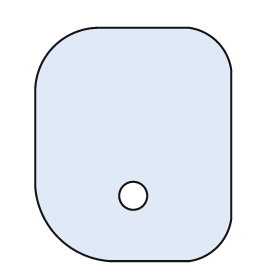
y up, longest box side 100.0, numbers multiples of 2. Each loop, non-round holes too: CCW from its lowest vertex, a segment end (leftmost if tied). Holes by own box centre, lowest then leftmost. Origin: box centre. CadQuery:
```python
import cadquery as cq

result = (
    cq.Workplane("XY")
    .moveTo(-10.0, -50.0)
    .lineTo(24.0, -50.0)
    .threePointArc((36.0, -44.0), (42.0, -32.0))
    .lineTo(42.0, 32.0)
    .threePointArc((36.0, 44.0), (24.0, 50.0))
    .lineTo(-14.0, 50.0)
    .threePointArc((-34.0, 42.0), (-42.0, 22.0))
    .lineTo(-42.0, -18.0)
    .threePointArc((-32.0, -40.0), (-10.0, -50.0))
    .close()
    .moveTo(0.0, -22.0)
    .circle(6.0)
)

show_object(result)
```